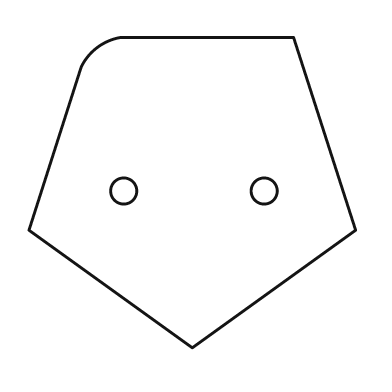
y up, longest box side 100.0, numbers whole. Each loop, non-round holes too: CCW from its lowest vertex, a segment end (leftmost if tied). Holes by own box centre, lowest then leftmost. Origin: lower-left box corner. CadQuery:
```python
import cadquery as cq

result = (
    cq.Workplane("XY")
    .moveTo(50.0, 0.0)
    .lineTo(100.0, 36.0)
    .lineTo(81.0, 95.0)
    .lineTo(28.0, 95.0)
    .threePointArc((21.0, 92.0), (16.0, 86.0))
    .lineTo(0.0, 36.0)
    .close()
    .moveTo(29.0, 48.0)
    .circle(4.0)
    .moveTo(72.0, 48.0)
    .circle(4.0)
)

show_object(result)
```